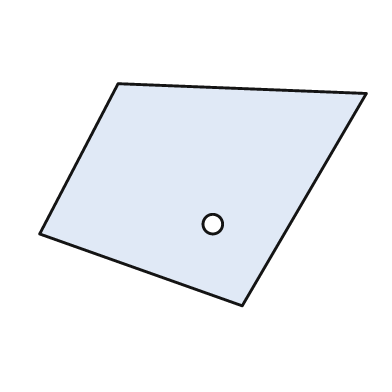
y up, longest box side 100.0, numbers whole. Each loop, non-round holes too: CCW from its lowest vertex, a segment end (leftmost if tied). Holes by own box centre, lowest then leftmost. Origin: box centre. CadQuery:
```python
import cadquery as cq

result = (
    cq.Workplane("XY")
    .moveTo(12.0, -34.0)
    .lineTo(50.0, 31.0)
    .lineTo(-26.0, 34.0)
    .lineTo(-50.0, -12.0)
    .close()
    .moveTo(3.0, -9.0)
    .circle(3.0)
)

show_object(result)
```